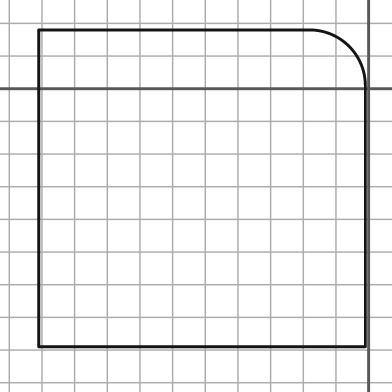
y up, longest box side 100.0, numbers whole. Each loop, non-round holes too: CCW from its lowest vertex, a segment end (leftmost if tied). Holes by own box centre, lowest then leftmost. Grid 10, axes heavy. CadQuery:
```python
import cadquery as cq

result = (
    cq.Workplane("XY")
    .moveTo(-101.0, -79.0)
    .lineTo(-1.0, -79.0)
    .lineTo(-1.0, 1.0)
    .threePointArc((-6.0, 13.0), (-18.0, 18.0))
    .lineTo(-101.0, 18.0)
    .close()
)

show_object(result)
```